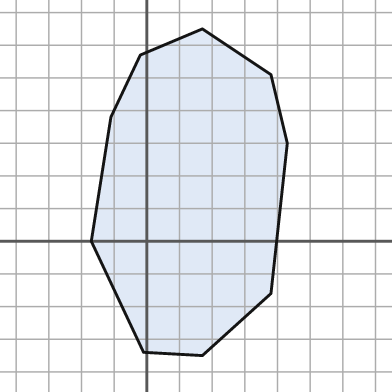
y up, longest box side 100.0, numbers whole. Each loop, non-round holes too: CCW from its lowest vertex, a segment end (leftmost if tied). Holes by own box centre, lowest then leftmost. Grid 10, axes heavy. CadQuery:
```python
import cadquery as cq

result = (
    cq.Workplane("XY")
    .moveTo(17.0, -35.0)
    .lineTo(38.0, -16.0)
    .lineTo(43.0, 30.0)
    .lineTo(38.0, 51.0)
    .lineTo(17.0, 65.0)
    .lineTo(-2.0, 57.0)
    .lineTo(-11.0, 38.0)
    .lineTo(-17.0, 0.0)
    .lineTo(-1.0, -34.0)
    .close()
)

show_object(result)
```